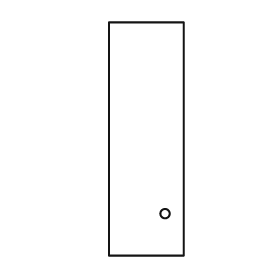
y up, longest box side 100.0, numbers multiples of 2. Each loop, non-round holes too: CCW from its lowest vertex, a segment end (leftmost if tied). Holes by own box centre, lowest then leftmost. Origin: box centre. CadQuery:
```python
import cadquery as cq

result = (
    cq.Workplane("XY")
    .moveTo(-16.0, -50.0)
    .lineTo(16.0, -50.0)
    .lineTo(16.0, 50.0)
    .lineTo(-16.0, 50.0)
    .close()
    .moveTo(8.0, -32.0)
    .circle(2.0)
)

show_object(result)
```